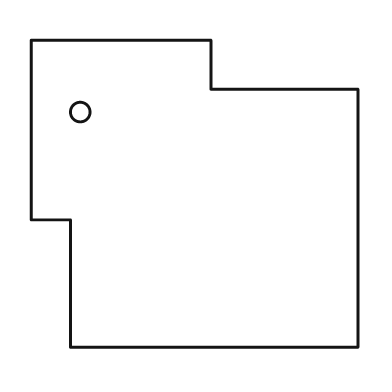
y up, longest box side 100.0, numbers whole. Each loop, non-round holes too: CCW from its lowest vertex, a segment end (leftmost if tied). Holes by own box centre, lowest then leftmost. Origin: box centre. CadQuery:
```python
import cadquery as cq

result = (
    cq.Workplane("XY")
    .moveTo(-38.0, -47.0)
    .lineTo(50.0, -47.0)
    .lineTo(50.0, 32.0)
    .lineTo(5.0, 32.0)
    .lineTo(5.0, 47.0)
    .lineTo(-50.0, 47.0)
    .lineTo(-50.0, -8.0)
    .lineTo(-38.0, -8.0)
    .close()
    .moveTo(-35.0, 25.0)
    .circle(3.0)
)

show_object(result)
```